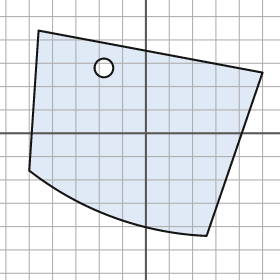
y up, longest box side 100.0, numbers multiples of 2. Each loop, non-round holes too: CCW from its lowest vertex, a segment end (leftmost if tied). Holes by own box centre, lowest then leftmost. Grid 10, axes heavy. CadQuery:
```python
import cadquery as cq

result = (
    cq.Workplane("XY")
    .moveTo(26.0, -44.0)
    .lineTo(50.0, 26.0)
    .lineTo(-46.0, 44.0)
    .lineTo(-50.0, -16.0)
    .threePointArc((-14.0, -36.0), (26.0, -44.0))
    .close()
    .moveTo(-18.0, 28.0)
    .circle(4.0)
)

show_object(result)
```